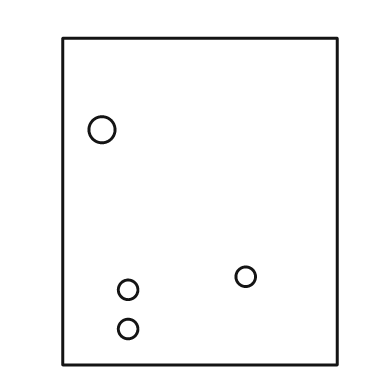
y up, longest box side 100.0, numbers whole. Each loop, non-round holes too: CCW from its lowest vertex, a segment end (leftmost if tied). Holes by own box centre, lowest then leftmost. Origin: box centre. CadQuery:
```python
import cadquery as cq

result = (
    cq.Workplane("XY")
    .moveTo(-42.0, -50.0)
    .lineTo(42.0, -50.0)
    .lineTo(42.0, 50.0)
    .lineTo(-42.0, 50.0)
    .close()
    .moveTo(-22.0, -39.0)
    .circle(3.0)
    .moveTo(-22.0, -27.0)
    .circle(3.0)
    .moveTo(14.0, -23.0)
    .circle(3.0)
    .moveTo(-30.0, 22.0)
    .circle(4.0)
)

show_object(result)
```